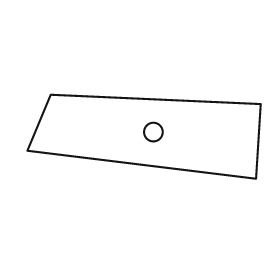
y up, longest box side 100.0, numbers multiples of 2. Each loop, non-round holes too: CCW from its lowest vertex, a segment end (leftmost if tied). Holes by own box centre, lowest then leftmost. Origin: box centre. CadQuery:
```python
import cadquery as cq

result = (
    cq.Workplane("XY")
    .moveTo(48.0, -18.0)
    .lineTo(50.0, 14.0)
    .lineTo(-40.0, 18.0)
    .lineTo(-50.0, -6.0)
    .close()
    .moveTo(4.0, 2.0)
    .circle(4.0)
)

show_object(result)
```